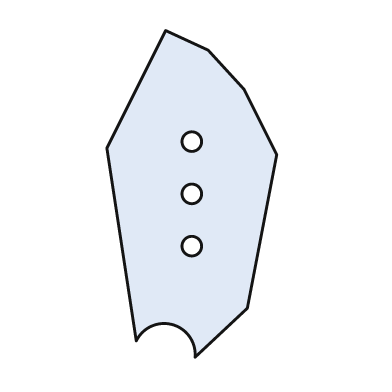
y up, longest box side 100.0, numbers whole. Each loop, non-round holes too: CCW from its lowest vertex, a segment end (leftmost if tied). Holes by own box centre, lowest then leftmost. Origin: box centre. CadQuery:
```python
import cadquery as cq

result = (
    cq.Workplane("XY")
    .moveTo(1.0, -50.0)
    .lineTo(17.0, -35.0)
    .lineTo(26.0, 12.0)
    .lineTo(16.0, 32.0)
    .lineTo(5.0, 44.0)
    .lineTo(-8.0, 50.0)
    .lineTo(-26.0, 14.0)
    .lineTo(-17.0, -45.0)
    .threePointArc((-6.0, -40.0), (1.0, -50.0))
    .close()
    .moveTo(0.0, -16.0)
    .circle(3.0)
    .moveTo(0.0, 0.0)
    .circle(3.0)
    .moveTo(0.0, 16.0)
    .circle(3.0)
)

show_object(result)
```